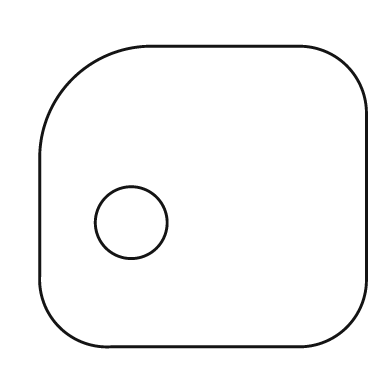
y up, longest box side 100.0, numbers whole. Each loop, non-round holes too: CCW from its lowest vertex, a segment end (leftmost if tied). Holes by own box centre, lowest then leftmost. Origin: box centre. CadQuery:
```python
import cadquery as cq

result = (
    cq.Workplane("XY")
    .moveTo(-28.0, -46.0)
    .lineTo(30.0, -46.0)
    .threePointArc((44.0, -40.0), (50.0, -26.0))
    .lineTo(50.0, 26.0)
    .threePointArc((44.0, 40.0), (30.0, 46.0))
    .lineTo(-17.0, 46.0)
    .threePointArc((-40.0, 36.0), (-50.0, 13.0))
    .lineTo(-50.0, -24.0)
    .threePointArc((-44.0, -40.0), (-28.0, -46.0))
    .close()
    .moveTo(-22.0, -8.0)
    .circle(11.0)
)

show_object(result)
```